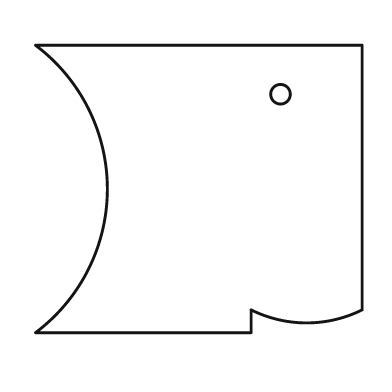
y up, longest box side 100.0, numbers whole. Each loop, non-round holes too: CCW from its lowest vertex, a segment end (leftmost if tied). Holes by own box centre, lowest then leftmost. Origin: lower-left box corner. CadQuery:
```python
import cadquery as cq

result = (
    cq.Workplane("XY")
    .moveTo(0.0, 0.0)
    .lineTo(66.0, 0.0)
    .lineTo(66.0, 7.0)
    .threePointArc((83.0, 3.0), (100.0, 7.0))
    .lineTo(100.0, 88.0)
    .lineTo(0.0, 88.0)
    .threePointArc((22.0, 44.0), (0.0, 0.0))
    .close()
    .moveTo(75.0, 73.0)
    .circle(3.0)
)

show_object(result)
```